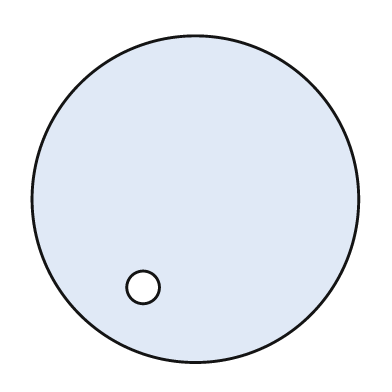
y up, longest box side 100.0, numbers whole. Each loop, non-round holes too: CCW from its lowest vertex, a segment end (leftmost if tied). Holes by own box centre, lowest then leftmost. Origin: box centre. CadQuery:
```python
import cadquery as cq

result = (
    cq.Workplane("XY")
    .moveTo(0.0, 0.0)
    .circle(50.0)
    .moveTo(-16.0, -27.0)
    .circle(5.0)
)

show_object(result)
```